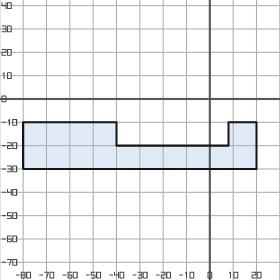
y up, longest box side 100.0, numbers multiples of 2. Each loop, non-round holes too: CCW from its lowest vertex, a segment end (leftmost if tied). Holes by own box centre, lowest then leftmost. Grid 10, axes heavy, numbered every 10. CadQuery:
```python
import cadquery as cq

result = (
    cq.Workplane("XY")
    .moveTo(-80.0, -30.0)
    .lineTo(20.0, -30.0)
    .lineTo(20.0, -10.0)
    .lineTo(8.0, -10.0)
    .lineTo(8.0, -20.0)
    .lineTo(-40.0, -20.0)
    .lineTo(-40.0, -10.0)
    .lineTo(-80.0, -10.0)
    .close()
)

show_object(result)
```